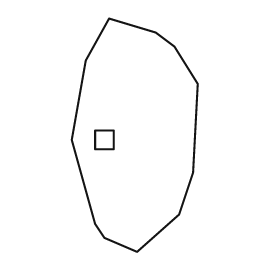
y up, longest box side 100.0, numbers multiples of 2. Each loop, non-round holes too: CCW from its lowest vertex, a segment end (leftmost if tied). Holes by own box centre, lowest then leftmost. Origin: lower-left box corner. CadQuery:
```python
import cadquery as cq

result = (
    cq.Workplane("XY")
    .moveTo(28.0, 0.0)
    .lineTo(46.0, 16.0)
    .lineTo(52.0, 34.0)
    .lineTo(54.0, 72.0)
    .lineTo(44.0, 88.0)
    .lineTo(36.0, 94.0)
    .lineTo(16.0, 100.0)
    .lineTo(6.0, 82.0)
    .lineTo(0.0, 48.0)
    .lineTo(10.0, 12.0)
    .lineTo(14.0, 6.0)
    .close()
    .moveTo(10.0, 44.0)
    .lineTo(18.0, 44.0)
    .lineTo(18.0, 52.0)
    .lineTo(10.0, 52.0)
    .close()
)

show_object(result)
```